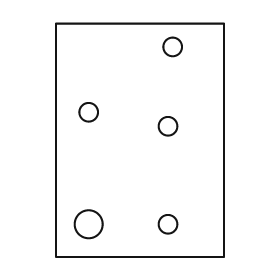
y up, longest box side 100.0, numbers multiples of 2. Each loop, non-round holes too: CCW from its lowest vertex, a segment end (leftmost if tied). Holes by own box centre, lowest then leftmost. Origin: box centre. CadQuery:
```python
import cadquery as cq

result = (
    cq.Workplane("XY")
    .moveTo(-36.0, -50.0)
    .lineTo(36.0, -50.0)
    .lineTo(36.0, 50.0)
    .lineTo(-36.0, 50.0)
    .close()
    .moveTo(-22.0, -36.0)
    .circle(6.0)
    .moveTo(12.0, -36.0)
    .circle(4.0)
    .moveTo(12.0, 6.0)
    .circle(4.0)
    .moveTo(-22.0, 12.0)
    .circle(4.0)
    .moveTo(14.0, 40.0)
    .circle(4.0)
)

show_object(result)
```